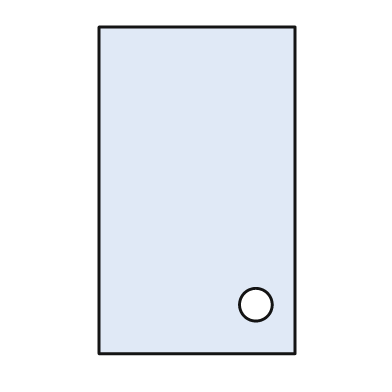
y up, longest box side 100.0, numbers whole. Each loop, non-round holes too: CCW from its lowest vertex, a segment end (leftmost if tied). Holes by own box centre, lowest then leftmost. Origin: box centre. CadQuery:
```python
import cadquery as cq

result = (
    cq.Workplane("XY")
    .moveTo(-30.0, -50.0)
    .lineTo(30.0, -50.0)
    .lineTo(30.0, 50.0)
    .lineTo(-30.0, 50.0)
    .close()
    .moveTo(18.0, -35.0)
    .circle(5.0)
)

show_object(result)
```